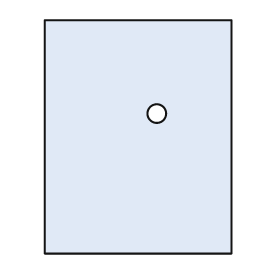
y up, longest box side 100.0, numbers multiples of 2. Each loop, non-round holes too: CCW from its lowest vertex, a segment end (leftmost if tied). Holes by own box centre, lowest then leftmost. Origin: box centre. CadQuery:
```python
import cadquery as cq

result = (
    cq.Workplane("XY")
    .moveTo(-40.0, -50.0)
    .lineTo(40.0, -50.0)
    .lineTo(40.0, 50.0)
    .lineTo(-40.0, 50.0)
    .close()
    .moveTo(8.0, 10.0)
    .circle(4.0)
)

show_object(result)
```